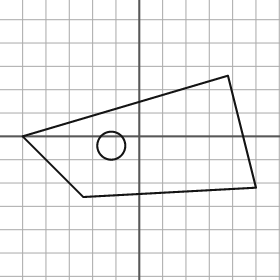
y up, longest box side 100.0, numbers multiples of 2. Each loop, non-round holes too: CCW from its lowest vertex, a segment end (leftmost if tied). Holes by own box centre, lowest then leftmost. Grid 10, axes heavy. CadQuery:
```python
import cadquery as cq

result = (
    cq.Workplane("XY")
    .moveTo(-24.0, -26.0)
    .lineTo(50.0, -22.0)
    .lineTo(38.0, 26.0)
    .lineTo(-50.0, 0.0)
    .close()
    .moveTo(-12.0, -4.0)
    .circle(6.0)
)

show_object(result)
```